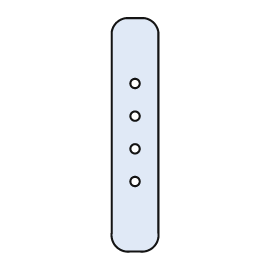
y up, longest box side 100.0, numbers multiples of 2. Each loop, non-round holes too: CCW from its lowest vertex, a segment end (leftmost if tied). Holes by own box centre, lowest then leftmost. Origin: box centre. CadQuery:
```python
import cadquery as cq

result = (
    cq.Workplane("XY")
    .moveTo(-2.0, -50.0)
    .lineTo(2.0, -50.0)
    .threePointArc((8.0, -48.0), (10.0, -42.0))
    .lineTo(10.0, 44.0)
    .threePointArc((8.0, 48.0), (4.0, 50.0))
    .lineTo(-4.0, 50.0)
    .threePointArc((-8.0, 48.0), (-10.0, 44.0))
    .lineTo(-10.0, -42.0)
    .threePointArc((-8.0, -48.0), (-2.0, -50.0))
    .close()
    .moveTo(0.0, -20.0)
    .circle(2.0)
    .moveTo(0.0, -6.0)
    .circle(2.0)
    .moveTo(0.0, 8.0)
    .circle(2.0)
    .moveTo(0.0, 22.0)
    .circle(2.0)
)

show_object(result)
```